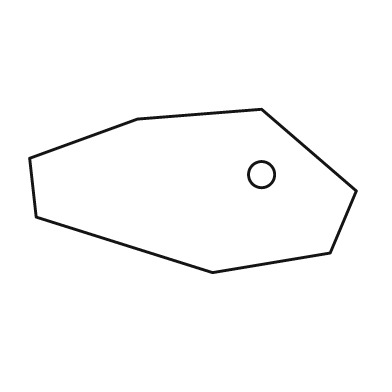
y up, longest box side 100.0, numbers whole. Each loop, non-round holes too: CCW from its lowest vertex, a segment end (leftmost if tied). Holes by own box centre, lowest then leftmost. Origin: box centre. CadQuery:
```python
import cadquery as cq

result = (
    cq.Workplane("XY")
    .moveTo(6.0, -25.0)
    .lineTo(42.0, -19.0)
    .lineTo(50.0, 0.0)
    .lineTo(21.0, 25.0)
    .lineTo(-17.0, 22.0)
    .lineTo(-50.0, 10.0)
    .lineTo(-48.0, -8.0)
    .close()
    .moveTo(21.0, 5.0)
    .circle(4.0)
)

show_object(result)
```